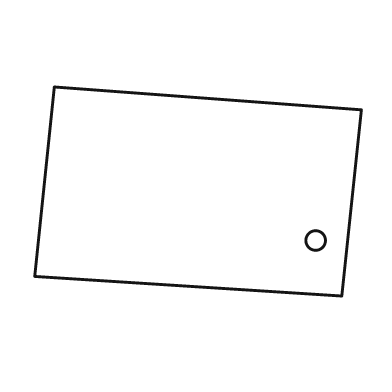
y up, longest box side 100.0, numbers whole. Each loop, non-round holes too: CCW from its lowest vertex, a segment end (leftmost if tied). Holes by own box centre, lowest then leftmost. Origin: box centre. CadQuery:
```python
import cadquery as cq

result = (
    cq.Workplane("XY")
    .moveTo(44.0, -32.0)
    .lineTo(50.0, 25.0)
    .lineTo(-44.0, 32.0)
    .lineTo(-50.0, -26.0)
    .close()
    .moveTo(36.0, -15.0)
    .circle(3.0)
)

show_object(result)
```